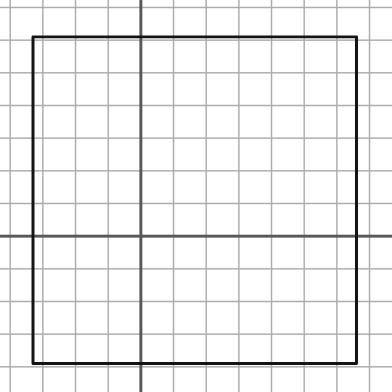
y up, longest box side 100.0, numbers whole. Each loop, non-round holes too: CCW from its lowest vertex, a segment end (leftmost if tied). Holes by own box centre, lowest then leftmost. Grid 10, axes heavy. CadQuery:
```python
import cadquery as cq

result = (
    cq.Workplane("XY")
    .moveTo(-33.0, -39.0)
    .lineTo(66.0, -39.0)
    .lineTo(66.0, 61.0)
    .lineTo(-33.0, 61.0)
    .close()
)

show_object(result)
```